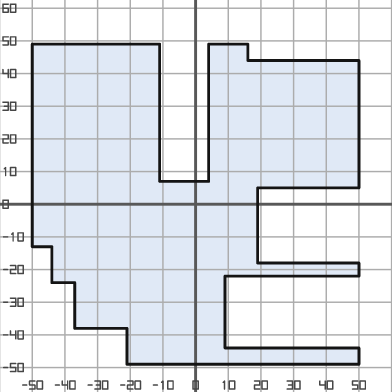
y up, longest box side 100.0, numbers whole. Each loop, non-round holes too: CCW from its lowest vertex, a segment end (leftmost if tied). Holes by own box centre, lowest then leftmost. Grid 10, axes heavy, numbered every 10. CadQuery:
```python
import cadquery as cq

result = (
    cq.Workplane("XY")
    .moveTo(-21.0, -49.0)
    .lineTo(50.0, -49.0)
    .lineTo(50.0, -44.0)
    .lineTo(9.0, -44.0)
    .lineTo(9.0, -22.0)
    .lineTo(50.0, -22.0)
    .lineTo(50.0, -18.0)
    .lineTo(19.0, -18.0)
    .lineTo(19.0, 5.0)
    .lineTo(50.0, 5.0)
    .lineTo(50.0, 44.0)
    .lineTo(16.0, 44.0)
    .lineTo(16.0, 49.0)
    .lineTo(4.0, 49.0)
    .lineTo(4.0, 7.0)
    .lineTo(-11.0, 7.0)
    .lineTo(-11.0, 49.0)
    .lineTo(-50.0, 49.0)
    .lineTo(-50.0, -13.0)
    .lineTo(-44.0, -13.0)
    .lineTo(-44.0, -24.0)
    .lineTo(-37.0, -24.0)
    .lineTo(-37.0, -38.0)
    .lineTo(-21.0, -38.0)
    .close()
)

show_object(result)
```